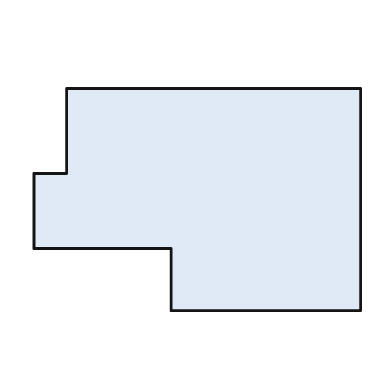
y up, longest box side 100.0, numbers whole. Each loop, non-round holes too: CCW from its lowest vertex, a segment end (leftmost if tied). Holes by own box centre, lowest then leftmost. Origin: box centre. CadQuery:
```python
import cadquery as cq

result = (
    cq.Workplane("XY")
    .moveTo(-8.0, -34.0)
    .lineTo(50.0, -34.0)
    .lineTo(50.0, 34.0)
    .lineTo(-40.0, 34.0)
    .lineTo(-40.0, 8.0)
    .lineTo(-50.0, 8.0)
    .lineTo(-50.0, -15.0)
    .lineTo(-8.0, -15.0)
    .close()
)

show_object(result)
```